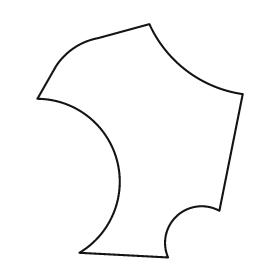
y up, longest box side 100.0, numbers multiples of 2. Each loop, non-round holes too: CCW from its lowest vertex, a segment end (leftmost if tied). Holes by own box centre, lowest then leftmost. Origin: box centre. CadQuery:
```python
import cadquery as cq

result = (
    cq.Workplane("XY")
    .moveTo(12.0, -50.0)
    .threePointArc((16.0, -32.0), (34.0, -30.0))
    .lineTo(44.0, 20.0)
    .threePointArc((20.0, 30.0), (4.0, 50.0))
    .lineTo(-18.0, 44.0)
    .threePointArc((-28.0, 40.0), (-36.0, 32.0))
    .lineTo(-44.0, 18.0)
    .threePointArc((-10.0, -8.0), (-26.0, -48.0))
    .close()
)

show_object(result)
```